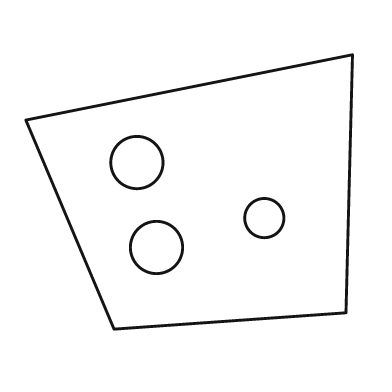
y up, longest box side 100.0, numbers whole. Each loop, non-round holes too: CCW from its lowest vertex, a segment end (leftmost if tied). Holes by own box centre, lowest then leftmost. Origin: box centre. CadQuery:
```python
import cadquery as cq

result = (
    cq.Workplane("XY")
    .moveTo(-23.0, -42.0)
    .lineTo(48.0, -37.0)
    .lineTo(50.0, 42.0)
    .lineTo(-50.0, 22.0)
    .close()
    .moveTo(-10.0, -17.0)
    .circle(8.0)
    .moveTo(23.0, -8.0)
    .circle(6.0)
    .moveTo(-16.0, 9.0)
    .circle(8.0)
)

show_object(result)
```